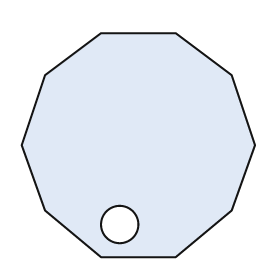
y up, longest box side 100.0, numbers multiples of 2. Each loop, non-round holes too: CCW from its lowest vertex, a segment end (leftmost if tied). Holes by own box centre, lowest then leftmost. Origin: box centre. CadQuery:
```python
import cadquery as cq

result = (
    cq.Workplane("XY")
    .moveTo(-16.0, -48.0)
    .lineTo(16.0, -48.0)
    .lineTo(40.0, -28.0)
    .lineTo(50.0, 0.0)
    .lineTo(40.0, 30.0)
    .lineTo(16.0, 48.0)
    .lineTo(-16.0, 48.0)
    .lineTo(-40.0, 30.0)
    .lineTo(-50.0, 0.0)
    .lineTo(-40.0, -28.0)
    .close()
    .moveTo(-8.0, -34.0)
    .circle(8.0)
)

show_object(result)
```